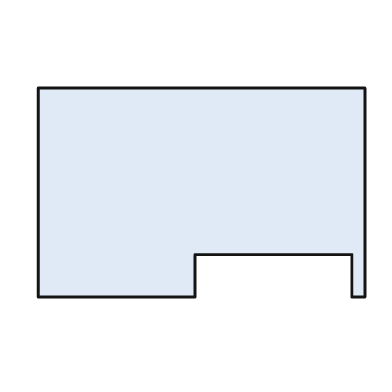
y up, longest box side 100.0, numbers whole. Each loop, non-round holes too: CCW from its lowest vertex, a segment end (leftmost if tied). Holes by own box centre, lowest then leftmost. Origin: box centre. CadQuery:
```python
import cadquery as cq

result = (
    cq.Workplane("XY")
    .moveTo(-50.0, -32.0)
    .lineTo(-2.0, -32.0)
    .lineTo(-2.0, -19.0)
    .lineTo(46.0, -19.0)
    .lineTo(46.0, -32.0)
    .lineTo(50.0, -32.0)
    .lineTo(50.0, 32.0)
    .lineTo(-50.0, 32.0)
    .close()
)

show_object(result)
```